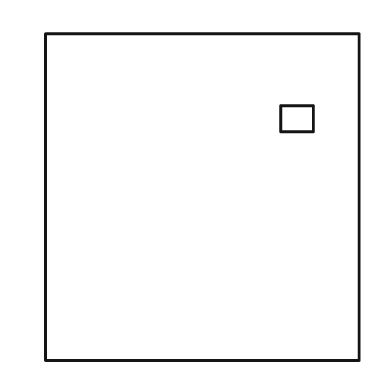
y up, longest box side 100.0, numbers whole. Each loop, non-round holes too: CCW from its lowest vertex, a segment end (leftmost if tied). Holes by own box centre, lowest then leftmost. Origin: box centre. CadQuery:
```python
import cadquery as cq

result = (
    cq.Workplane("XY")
    .moveTo(-48.0, -50.0)
    .lineTo(48.0, -50.0)
    .lineTo(48.0, 50.0)
    .lineTo(-48.0, 50.0)
    .close()
    .moveTo(24.0, 20.0)
    .lineTo(34.0, 20.0)
    .lineTo(34.0, 28.0)
    .lineTo(24.0, 28.0)
    .close()
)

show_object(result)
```